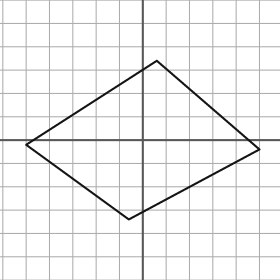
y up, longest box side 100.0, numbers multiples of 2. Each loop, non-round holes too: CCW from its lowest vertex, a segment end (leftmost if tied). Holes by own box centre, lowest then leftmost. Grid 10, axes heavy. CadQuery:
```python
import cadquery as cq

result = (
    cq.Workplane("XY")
    .moveTo(-6.0, -34.0)
    .lineTo(50.0, -4.0)
    .lineTo(6.0, 34.0)
    .lineTo(-50.0, -2.0)
    .close()
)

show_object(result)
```